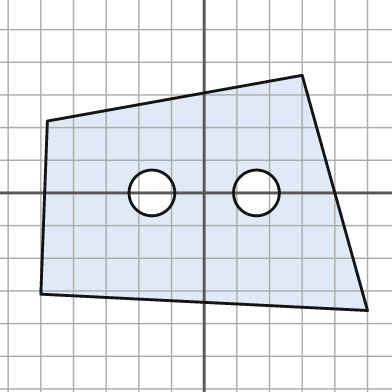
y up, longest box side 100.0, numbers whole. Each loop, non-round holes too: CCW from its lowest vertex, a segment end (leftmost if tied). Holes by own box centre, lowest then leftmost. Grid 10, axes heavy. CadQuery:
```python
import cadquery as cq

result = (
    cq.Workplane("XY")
    .moveTo(50.0, -36.0)
    .lineTo(30.0, 36.0)
    .lineTo(-48.0, 22.0)
    .lineTo(-50.0, -31.0)
    .close()
    .moveTo(-16.0, 0.0)
    .circle(7.0)
    .moveTo(16.0, 0.0)
    .circle(7.0)
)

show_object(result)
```